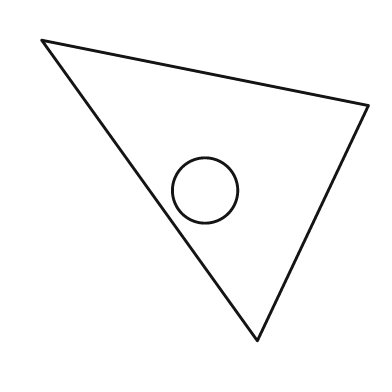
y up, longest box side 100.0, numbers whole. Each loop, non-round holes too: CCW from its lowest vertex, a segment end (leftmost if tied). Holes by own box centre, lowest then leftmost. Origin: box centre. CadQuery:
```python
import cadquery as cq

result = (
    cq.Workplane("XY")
    .moveTo(16.0, -46.0)
    .lineTo(50.0, 26.0)
    .lineTo(-50.0, 46.0)
    .close()
    .moveTo(0.0, 0.0)
    .circle(10.0)
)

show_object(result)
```